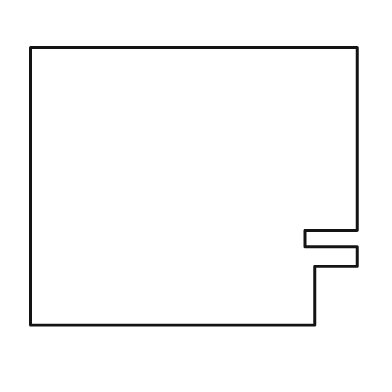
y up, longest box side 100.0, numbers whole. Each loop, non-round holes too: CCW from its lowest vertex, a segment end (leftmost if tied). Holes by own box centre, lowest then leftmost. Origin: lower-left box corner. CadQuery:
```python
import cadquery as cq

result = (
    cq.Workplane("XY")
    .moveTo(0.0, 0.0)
    .lineTo(87.0, 0.0)
    .lineTo(87.0, 18.0)
    .lineTo(100.0, 18.0)
    .lineTo(100.0, 24.0)
    .lineTo(84.0, 24.0)
    .lineTo(84.0, 29.0)
    .lineTo(100.0, 29.0)
    .lineTo(100.0, 85.0)
    .lineTo(0.0, 85.0)
    .close()
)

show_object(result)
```